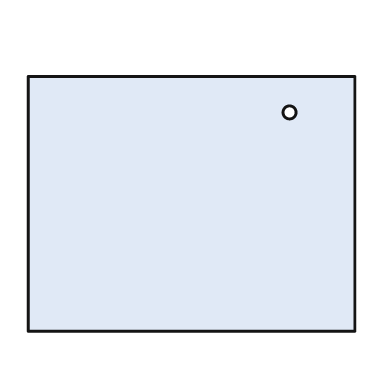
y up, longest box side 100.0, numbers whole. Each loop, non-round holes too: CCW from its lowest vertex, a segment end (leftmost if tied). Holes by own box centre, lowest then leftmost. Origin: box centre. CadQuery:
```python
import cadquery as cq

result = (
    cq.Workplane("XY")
    .moveTo(-50.0, -39.0)
    .lineTo(50.0, -39.0)
    .lineTo(50.0, 39.0)
    .lineTo(-50.0, 39.0)
    .close()
    .moveTo(30.0, 28.0)
    .circle(2.0)
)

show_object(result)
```